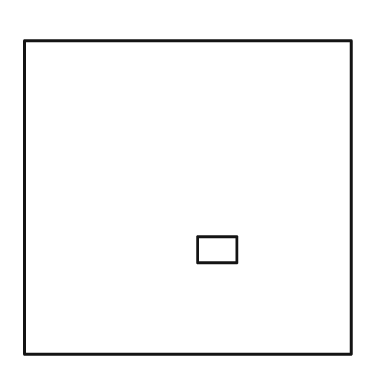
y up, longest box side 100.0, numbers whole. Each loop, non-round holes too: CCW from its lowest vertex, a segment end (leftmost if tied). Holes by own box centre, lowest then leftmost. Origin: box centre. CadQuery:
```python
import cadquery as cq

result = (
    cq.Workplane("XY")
    .moveTo(-50.0, -48.0)
    .lineTo(50.0, -48.0)
    .lineTo(50.0, 48.0)
    .lineTo(-50.0, 48.0)
    .close()
    .moveTo(3.0, -20.0)
    .lineTo(15.0, -20.0)
    .lineTo(15.0, -12.0)
    .lineTo(3.0, -12.0)
    .close()
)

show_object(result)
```